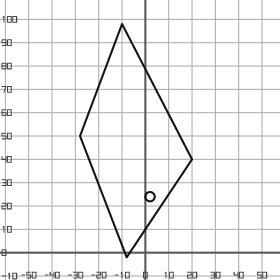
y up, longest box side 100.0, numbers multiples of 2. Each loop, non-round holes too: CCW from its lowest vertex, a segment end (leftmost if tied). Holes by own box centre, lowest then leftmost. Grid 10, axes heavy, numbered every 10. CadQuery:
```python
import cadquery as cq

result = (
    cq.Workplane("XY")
    .moveTo(-8.0, -2.0)
    .lineTo(20.0, 40.0)
    .lineTo(-10.0, 98.0)
    .lineTo(-28.0, 50.0)
    .close()
    .moveTo(2.0, 24.0)
    .circle(2.0)
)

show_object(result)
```